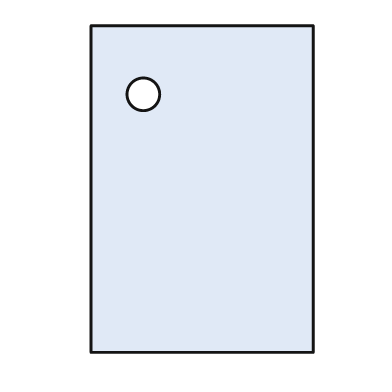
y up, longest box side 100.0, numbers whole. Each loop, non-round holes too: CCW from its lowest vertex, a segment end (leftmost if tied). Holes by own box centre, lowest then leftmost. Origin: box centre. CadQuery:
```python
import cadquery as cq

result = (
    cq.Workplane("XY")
    .moveTo(-34.0, -50.0)
    .lineTo(34.0, -50.0)
    .lineTo(34.0, 50.0)
    .lineTo(-34.0, 50.0)
    .close()
    .moveTo(-18.0, 29.0)
    .circle(5.0)
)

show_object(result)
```